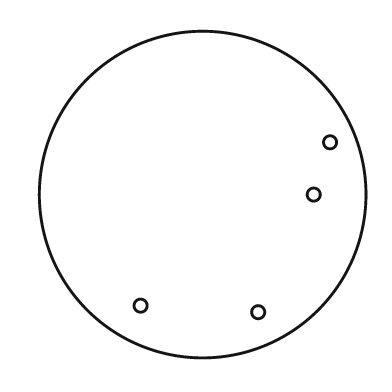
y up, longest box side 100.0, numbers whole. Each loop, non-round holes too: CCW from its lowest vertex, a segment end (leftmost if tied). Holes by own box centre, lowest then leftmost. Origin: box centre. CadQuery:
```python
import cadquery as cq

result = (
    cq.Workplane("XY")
    .moveTo(0.0, 0.0)
    .circle(50.0)
    .moveTo(17.0, -36.0)
    .circle(2.0)
    .moveTo(-19.0, -34.0)
    .circle(2.0)
    .moveTo(34.0, 0.0)
    .circle(2.0)
    .moveTo(39.0, 16.0)
    .circle(2.0)
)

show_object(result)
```